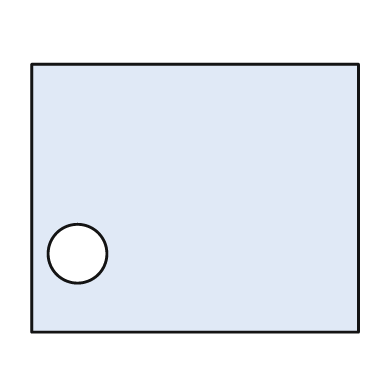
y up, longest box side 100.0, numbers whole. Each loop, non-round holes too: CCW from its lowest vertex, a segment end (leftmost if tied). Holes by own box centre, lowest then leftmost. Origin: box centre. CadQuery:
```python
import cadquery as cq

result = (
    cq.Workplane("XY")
    .moveTo(-50.0, -41.0)
    .lineTo(50.0, -41.0)
    .lineTo(50.0, 41.0)
    .lineTo(-50.0, 41.0)
    .close()
    .moveTo(-36.0, -17.0)
    .circle(9.0)
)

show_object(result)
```